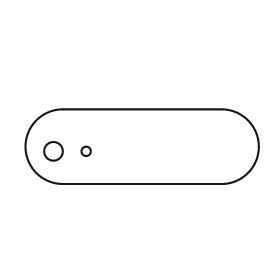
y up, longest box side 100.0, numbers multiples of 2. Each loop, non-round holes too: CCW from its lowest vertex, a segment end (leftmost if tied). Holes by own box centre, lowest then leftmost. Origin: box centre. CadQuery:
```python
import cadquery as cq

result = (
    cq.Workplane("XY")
    .moveTo(-34.0, -16.0)
    .lineTo(34.0, -16.0)
    .threePointArc((50.0, 0.0), (34.0, 16.0))
    .lineTo(-34.0, 16.0)
    .threePointArc((-50.0, 0.0), (-34.0, -16.0))
    .close()
    .moveTo(-38.0, -2.0)
    .circle(4.0)
    .moveTo(-24.0, -2.0)
    .circle(2.0)
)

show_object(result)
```